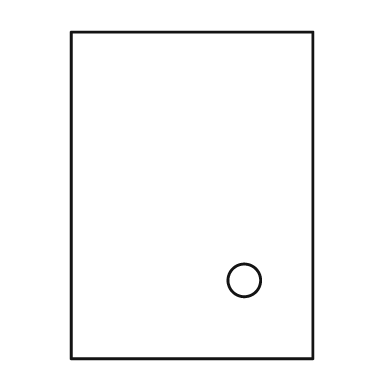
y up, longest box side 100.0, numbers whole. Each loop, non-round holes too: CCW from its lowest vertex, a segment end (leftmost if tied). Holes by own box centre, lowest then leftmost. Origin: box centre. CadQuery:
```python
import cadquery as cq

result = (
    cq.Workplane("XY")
    .moveTo(-37.0, -50.0)
    .lineTo(37.0, -50.0)
    .lineTo(37.0, 50.0)
    .lineTo(-37.0, 50.0)
    .close()
    .moveTo(16.0, -26.0)
    .circle(5.0)
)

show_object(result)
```